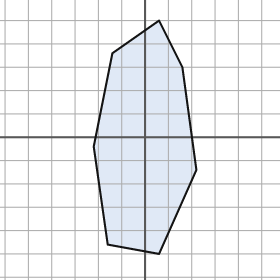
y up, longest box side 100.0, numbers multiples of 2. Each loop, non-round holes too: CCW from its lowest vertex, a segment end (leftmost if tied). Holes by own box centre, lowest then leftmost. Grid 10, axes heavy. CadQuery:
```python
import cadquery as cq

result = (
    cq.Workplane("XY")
    .moveTo(6.0, -50.0)
    .lineTo(22.0, -14.0)
    .lineTo(16.0, 30.0)
    .lineTo(6.0, 50.0)
    .lineTo(-14.0, 36.0)
    .lineTo(-22.0, -4.0)
    .lineTo(-16.0, -46.0)
    .close()
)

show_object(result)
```